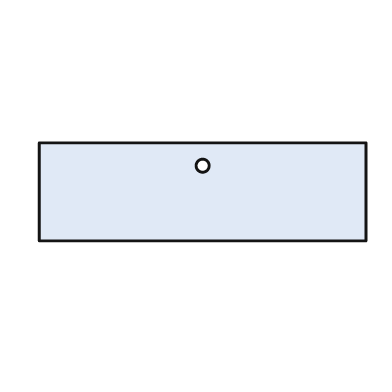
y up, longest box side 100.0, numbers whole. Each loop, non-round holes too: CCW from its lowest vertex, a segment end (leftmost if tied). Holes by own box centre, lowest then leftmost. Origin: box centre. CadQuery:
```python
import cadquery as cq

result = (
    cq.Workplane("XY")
    .moveTo(-50.0, -15.0)
    .lineTo(50.0, -15.0)
    .lineTo(50.0, 15.0)
    .lineTo(-50.0, 15.0)
    .close()
    .moveTo(0.0, 8.0)
    .circle(2.0)
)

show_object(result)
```